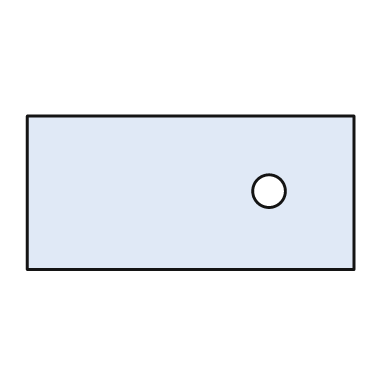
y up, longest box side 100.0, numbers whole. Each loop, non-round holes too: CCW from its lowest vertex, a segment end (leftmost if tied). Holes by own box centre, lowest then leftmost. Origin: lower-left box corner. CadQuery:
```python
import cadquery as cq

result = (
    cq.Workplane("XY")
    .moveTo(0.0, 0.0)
    .lineTo(100.0, 0.0)
    .lineTo(100.0, 47.0)
    .lineTo(0.0, 47.0)
    .close()
    .moveTo(74.0, 24.0)
    .circle(5.0)
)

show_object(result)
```